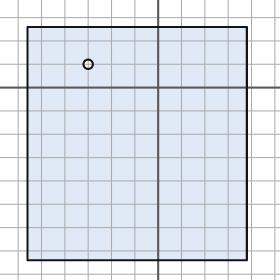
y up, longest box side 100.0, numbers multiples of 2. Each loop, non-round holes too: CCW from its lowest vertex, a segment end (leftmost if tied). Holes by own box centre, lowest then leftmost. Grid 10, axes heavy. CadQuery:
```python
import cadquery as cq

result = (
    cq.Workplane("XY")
    .moveTo(-56.0, -74.0)
    .lineTo(38.0, -74.0)
    .lineTo(38.0, 26.0)
    .lineTo(-56.0, 26.0)
    .close()
    .moveTo(-30.0, 10.0)
    .circle(2.0)
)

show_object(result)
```